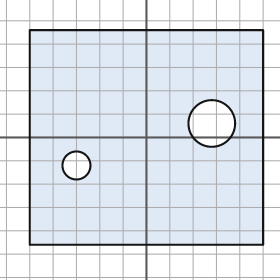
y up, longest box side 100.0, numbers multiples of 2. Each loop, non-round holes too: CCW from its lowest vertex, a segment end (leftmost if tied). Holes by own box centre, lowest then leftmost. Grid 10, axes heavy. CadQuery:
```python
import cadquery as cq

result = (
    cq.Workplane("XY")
    .moveTo(-50.0, -46.0)
    .lineTo(50.0, -46.0)
    .lineTo(50.0, 46.0)
    .lineTo(-50.0, 46.0)
    .close()
    .moveTo(-30.0, -12.0)
    .circle(6.0)
    .moveTo(28.0, 6.0)
    .circle(10.0)
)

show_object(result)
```